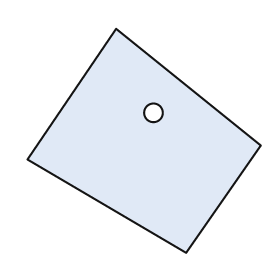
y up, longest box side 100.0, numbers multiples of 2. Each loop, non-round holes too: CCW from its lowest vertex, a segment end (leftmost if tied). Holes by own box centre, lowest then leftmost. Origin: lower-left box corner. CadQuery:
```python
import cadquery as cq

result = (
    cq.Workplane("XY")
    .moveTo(68.0, 0.0)
    .lineTo(100.0, 46.0)
    .lineTo(38.0, 96.0)
    .lineTo(0.0, 40.0)
    .close()
    .moveTo(54.0, 60.0)
    .circle(4.0)
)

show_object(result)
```